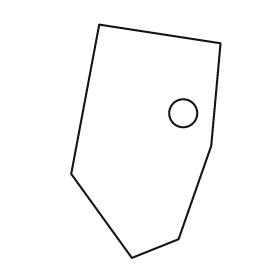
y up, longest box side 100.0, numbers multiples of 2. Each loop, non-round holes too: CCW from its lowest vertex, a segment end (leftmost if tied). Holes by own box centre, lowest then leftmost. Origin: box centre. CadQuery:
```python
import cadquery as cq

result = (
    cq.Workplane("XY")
    .moveTo(-6.0, -50.0)
    .lineTo(14.0, -42.0)
    .lineTo(28.0, -2.0)
    .lineTo(32.0, 42.0)
    .lineTo(-20.0, 50.0)
    .lineTo(-32.0, -14.0)
    .close()
    .moveTo(16.0, 12.0)
    .circle(6.0)
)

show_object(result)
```